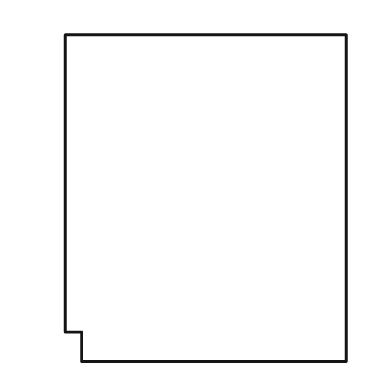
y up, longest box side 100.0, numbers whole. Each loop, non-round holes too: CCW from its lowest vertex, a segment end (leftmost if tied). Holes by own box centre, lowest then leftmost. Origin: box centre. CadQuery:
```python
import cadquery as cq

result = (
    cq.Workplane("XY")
    .moveTo(-38.0, -50.0)
    .lineTo(43.0, -50.0)
    .lineTo(43.0, 50.0)
    .lineTo(-43.0, 50.0)
    .lineTo(-43.0, -41.0)
    .lineTo(-38.0, -41.0)
    .close()
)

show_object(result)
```